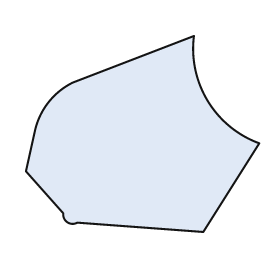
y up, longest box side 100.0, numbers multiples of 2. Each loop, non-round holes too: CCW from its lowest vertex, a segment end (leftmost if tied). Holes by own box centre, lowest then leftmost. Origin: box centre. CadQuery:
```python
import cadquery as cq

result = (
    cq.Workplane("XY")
    .moveTo(26.0, -42.0)
    .lineTo(50.0, -4.0)
    .threePointArc((28.0, 14.0), (22.0, 42.0))
    .lineTo(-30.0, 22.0)
    .threePointArc((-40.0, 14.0), (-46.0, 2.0))
    .lineTo(-50.0, -16.0)
    .lineTo(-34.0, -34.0)
    .threePointArc((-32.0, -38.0), (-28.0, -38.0))
    .close()
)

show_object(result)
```